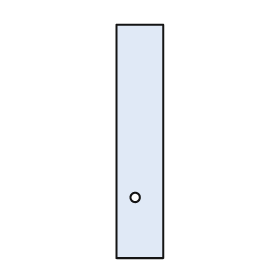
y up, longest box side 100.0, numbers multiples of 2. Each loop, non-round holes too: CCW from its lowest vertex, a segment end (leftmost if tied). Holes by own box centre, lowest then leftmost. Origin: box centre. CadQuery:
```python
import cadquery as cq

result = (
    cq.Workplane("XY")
    .moveTo(-10.0, -50.0)
    .lineTo(10.0, -50.0)
    .lineTo(10.0, 50.0)
    .lineTo(-10.0, 50.0)
    .close()
    .moveTo(-2.0, -24.0)
    .circle(2.0)
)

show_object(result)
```